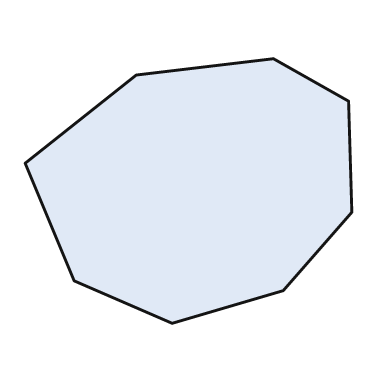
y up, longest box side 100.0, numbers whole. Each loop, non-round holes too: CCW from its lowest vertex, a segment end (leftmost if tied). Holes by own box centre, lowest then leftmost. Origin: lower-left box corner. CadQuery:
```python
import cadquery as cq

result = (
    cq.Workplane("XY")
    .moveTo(45.0, 0.0)
    .lineTo(79.0, 10.0)
    .lineTo(100.0, 34.0)
    .lineTo(99.0, 68.0)
    .lineTo(76.0, 81.0)
    .lineTo(34.0, 76.0)
    .lineTo(0.0, 49.0)
    .lineTo(15.0, 13.0)
    .close()
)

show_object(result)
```